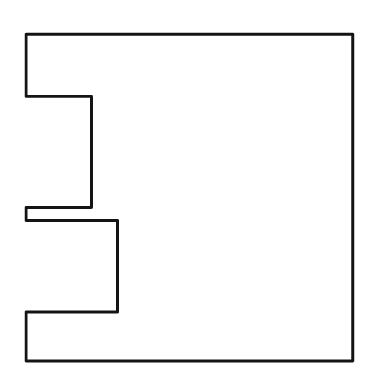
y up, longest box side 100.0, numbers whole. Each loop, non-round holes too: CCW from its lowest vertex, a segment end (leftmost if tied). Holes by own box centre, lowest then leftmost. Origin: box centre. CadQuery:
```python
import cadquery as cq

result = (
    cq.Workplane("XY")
    .moveTo(-50.0, -50.0)
    .lineTo(50.0, -50.0)
    .lineTo(50.0, 50.0)
    .lineTo(-50.0, 50.0)
    .lineTo(-50.0, 31.0)
    .lineTo(-30.0, 31.0)
    .lineTo(-30.0, -3.0)
    .lineTo(-50.0, -3.0)
    .lineTo(-50.0, -7.0)
    .lineTo(-22.0, -7.0)
    .lineTo(-22.0, -35.0)
    .lineTo(-50.0, -35.0)
    .close()
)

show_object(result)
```